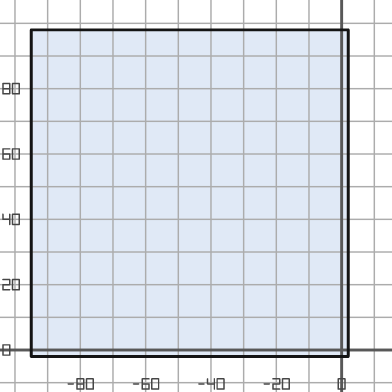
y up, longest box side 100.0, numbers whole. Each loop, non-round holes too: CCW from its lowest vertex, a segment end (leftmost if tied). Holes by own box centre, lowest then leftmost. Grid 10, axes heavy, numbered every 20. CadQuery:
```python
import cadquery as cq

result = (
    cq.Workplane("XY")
    .moveTo(-95.0, -2.0)
    .lineTo(2.0, -2.0)
    .lineTo(2.0, 98.0)
    .lineTo(-95.0, 98.0)
    .close()
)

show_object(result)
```